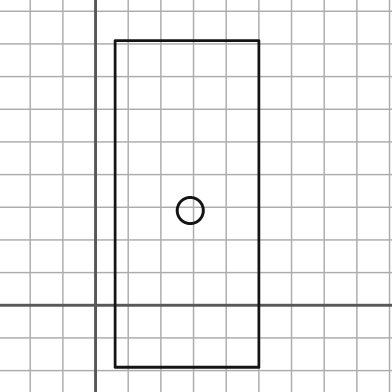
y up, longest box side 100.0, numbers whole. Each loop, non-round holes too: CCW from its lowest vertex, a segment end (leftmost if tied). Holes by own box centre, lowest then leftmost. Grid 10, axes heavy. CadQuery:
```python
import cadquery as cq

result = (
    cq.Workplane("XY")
    .moveTo(6.0, -19.0)
    .lineTo(50.0, -19.0)
    .lineTo(50.0, 81.0)
    .lineTo(6.0, 81.0)
    .close()
    .moveTo(29.0, 29.0)
    .circle(4.0)
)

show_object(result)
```